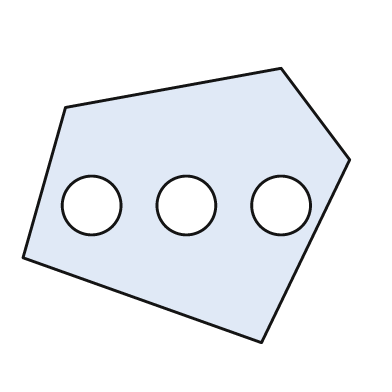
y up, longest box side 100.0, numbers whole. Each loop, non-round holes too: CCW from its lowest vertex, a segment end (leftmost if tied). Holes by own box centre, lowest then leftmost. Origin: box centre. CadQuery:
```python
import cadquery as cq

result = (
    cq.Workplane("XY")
    .moveTo(23.0, -42.0)
    .lineTo(50.0, 14.0)
    .lineTo(29.0, 42.0)
    .lineTo(-37.0, 30.0)
    .lineTo(-50.0, -16.0)
    .close()
    .moveTo(-29.0, 0.0)
    .circle(9.0)
    .moveTo(0.0, 0.0)
    .circle(9.0)
    .moveTo(29.0, 0.0)
    .circle(9.0)
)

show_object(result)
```